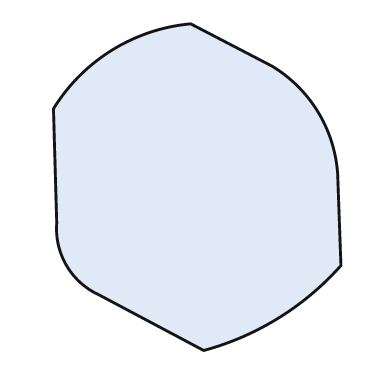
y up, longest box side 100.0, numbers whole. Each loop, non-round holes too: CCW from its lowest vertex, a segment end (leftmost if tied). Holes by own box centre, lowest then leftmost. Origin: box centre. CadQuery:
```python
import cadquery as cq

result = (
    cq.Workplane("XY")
    .moveTo(2.0, -50.0)
    .threePointArc((25.0, -40.0), (44.0, -24.0))
    .lineTo(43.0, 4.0)
    .threePointArc((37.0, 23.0), (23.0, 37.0))
    .lineTo(-2.0, 50.0)
    .threePointArc((-26.0, 42.0), (-44.0, 24.0))
    .lineTo(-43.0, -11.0)
    .threePointArc((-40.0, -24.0), (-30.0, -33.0))
    .close()
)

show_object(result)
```